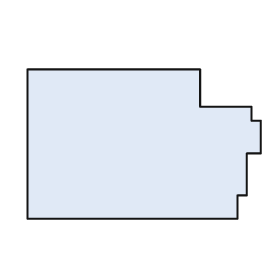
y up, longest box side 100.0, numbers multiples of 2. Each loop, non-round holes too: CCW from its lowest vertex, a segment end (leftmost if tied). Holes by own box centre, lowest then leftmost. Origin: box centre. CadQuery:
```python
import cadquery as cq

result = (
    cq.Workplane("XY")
    .moveTo(-50.0, -32.0)
    .lineTo(40.0, -32.0)
    .lineTo(40.0, -22.0)
    .lineTo(44.0, -22.0)
    .lineTo(44.0, -4.0)
    .lineTo(50.0, -4.0)
    .lineTo(50.0, 10.0)
    .lineTo(46.0, 10.0)
    .lineTo(46.0, 16.0)
    .lineTo(24.0, 16.0)
    .lineTo(24.0, 32.0)
    .lineTo(-50.0, 32.0)
    .close()
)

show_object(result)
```